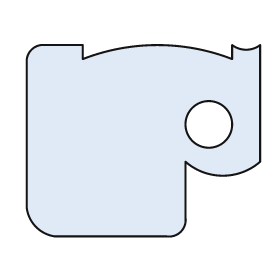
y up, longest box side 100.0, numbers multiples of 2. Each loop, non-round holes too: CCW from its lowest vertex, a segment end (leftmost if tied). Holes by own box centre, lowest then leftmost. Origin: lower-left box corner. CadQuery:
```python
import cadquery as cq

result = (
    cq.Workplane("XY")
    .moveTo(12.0, 0.0)
    .lineTo(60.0, 0.0)
    .threePointArc((66.0, 2.0), (68.0, 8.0))
    .lineTo(68.0, 32.0)
    .threePointArc((84.0, 26.0), (100.0, 32.0))
    .lineTo(100.0, 82.0)
    .threePointArc((94.0, 80.0), (88.0, 82.0))
    .lineTo(88.0, 76.0)
    .threePointArc((56.0, 82.0), (24.0, 76.0))
    .lineTo(24.0, 82.0)
    .lineTo(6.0, 82.0)
    .threePointArc((2.0, 80.0), (0.0, 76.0))
    .lineTo(0.0, 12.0)
    .threePointArc((4.0, 4.0), (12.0, 0.0))
    .close()
    .moveTo(78.0, 48.0)
    .circle(10.0)
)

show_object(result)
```